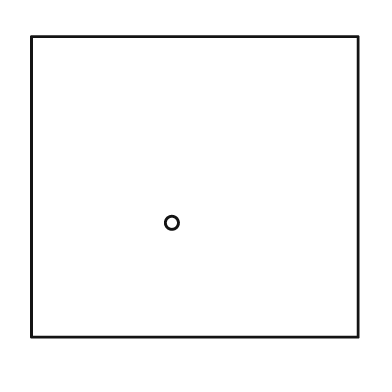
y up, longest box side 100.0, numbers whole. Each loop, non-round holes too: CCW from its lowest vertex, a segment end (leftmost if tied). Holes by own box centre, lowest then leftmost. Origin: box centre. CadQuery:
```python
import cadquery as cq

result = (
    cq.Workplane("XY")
    .moveTo(-50.0, -46.0)
    .lineTo(50.0, -46.0)
    .lineTo(50.0, 46.0)
    .lineTo(-50.0, 46.0)
    .close()
    .moveTo(-7.0, -11.0)
    .circle(2.0)
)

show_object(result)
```